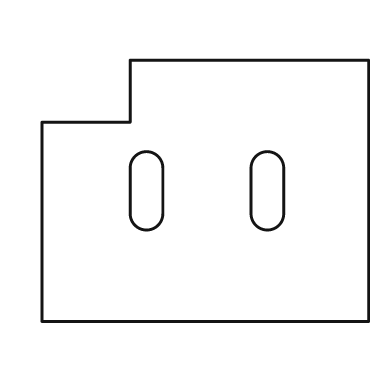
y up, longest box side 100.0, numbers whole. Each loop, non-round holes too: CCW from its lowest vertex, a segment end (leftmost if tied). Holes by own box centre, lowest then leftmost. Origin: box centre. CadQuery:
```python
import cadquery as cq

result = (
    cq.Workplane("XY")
    .moveTo(-50.0, -40.0)
    .lineTo(50.0, -40.0)
    .lineTo(50.0, 40.0)
    .lineTo(-23.0, 40.0)
    .lineTo(-23.0, 21.0)
    .lineTo(-50.0, 21.0)
    .close()
    .moveTo(-23.0, -7.0)
    .threePointArc((-18.0, -12.0), (-13.0, -7.0))
    .lineTo(-13.0, 7.0)
    .threePointArc((-18.0, 12.0), (-23.0, 7.0))
    .close()
    .moveTo(14.0, -7.0)
    .threePointArc((19.0, -12.0), (24.0, -7.0))
    .lineTo(24.0, 7.0)
    .threePointArc((19.0, 12.0), (14.0, 7.0))
    .close()
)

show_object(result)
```